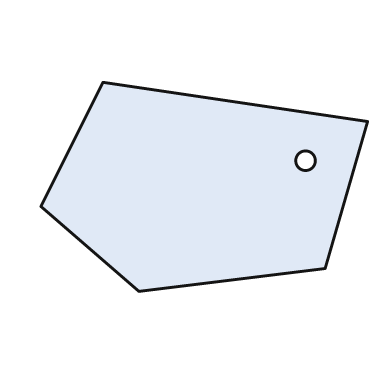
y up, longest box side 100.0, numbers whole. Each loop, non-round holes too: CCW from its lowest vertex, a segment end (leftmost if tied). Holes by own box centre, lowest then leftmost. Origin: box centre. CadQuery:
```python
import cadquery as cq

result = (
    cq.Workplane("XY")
    .moveTo(-20.0, -32.0)
    .lineTo(37.0, -25.0)
    .lineTo(50.0, 20.0)
    .lineTo(-31.0, 32.0)
    .lineTo(-50.0, -6.0)
    .close()
    .moveTo(31.0, 8.0)
    .circle(3.0)
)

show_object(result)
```